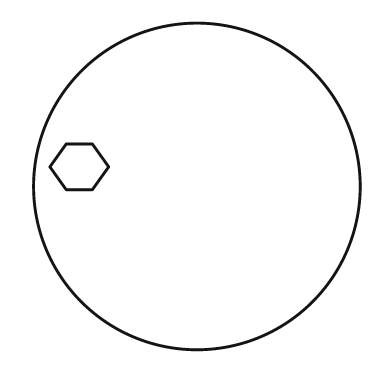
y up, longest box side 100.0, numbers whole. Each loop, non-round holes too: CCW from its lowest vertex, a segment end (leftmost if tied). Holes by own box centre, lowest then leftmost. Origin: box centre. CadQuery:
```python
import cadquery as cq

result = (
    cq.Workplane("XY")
    .moveTo(0.0, 0.0)
    .circle(50.0)
    .moveTo(-40.0, -1.0)
    .lineTo(-32.0, -1.0)
    .lineTo(-27.0, 6.0)
    .lineTo(-32.0, 13.0)
    .lineTo(-40.0, 13.0)
    .lineTo(-45.0, 6.0)
    .close()
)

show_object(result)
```